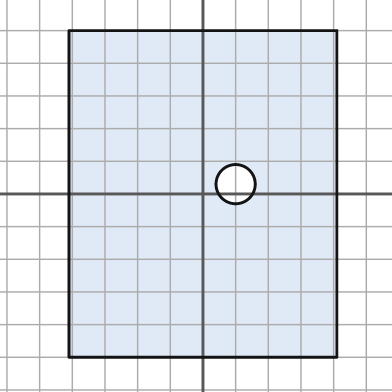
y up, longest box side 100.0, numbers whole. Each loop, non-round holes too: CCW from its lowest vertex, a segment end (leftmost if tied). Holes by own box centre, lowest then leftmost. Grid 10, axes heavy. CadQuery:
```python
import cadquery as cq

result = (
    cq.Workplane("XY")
    .moveTo(-41.0, -50.0)
    .lineTo(41.0, -50.0)
    .lineTo(41.0, 50.0)
    .lineTo(-41.0, 50.0)
    .close()
    .moveTo(10.0, 3.0)
    .circle(6.0)
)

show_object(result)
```